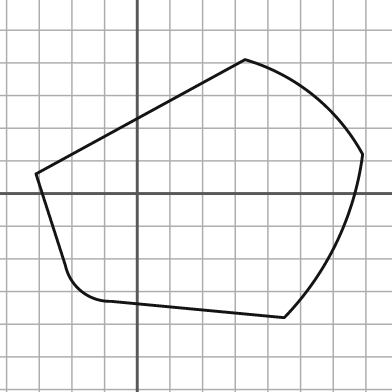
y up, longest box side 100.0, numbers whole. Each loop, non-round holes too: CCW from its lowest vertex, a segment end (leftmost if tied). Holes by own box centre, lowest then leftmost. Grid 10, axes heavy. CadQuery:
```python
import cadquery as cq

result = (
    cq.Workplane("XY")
    .moveTo(45.0, -38.0)
    .threePointArc((61.0, -15.0), (69.0, 12.0))
    .threePointArc((54.0, 30.0), (33.0, 41.0))
    .lineTo(-31.0, 6.0)
    .lineTo(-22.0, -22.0)
    .threePointArc((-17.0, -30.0), (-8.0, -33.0))
    .close()
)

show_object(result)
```